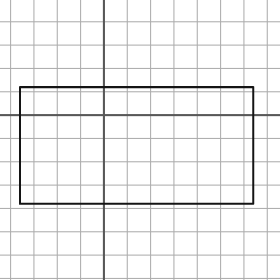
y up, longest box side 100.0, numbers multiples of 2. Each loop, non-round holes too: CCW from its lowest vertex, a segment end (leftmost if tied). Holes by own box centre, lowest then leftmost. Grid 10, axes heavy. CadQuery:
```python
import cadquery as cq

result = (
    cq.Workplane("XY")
    .moveTo(-36.0, -38.0)
    .lineTo(64.0, -38.0)
    .lineTo(64.0, 12.0)
    .lineTo(-36.0, 12.0)
    .close()
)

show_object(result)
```